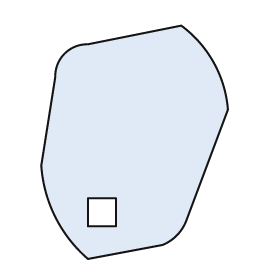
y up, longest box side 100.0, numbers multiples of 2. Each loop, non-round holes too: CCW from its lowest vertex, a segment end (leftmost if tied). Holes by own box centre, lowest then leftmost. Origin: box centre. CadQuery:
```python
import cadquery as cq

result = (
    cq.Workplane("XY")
    .moveTo(-20.0, -50.0)
    .lineTo(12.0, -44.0)
    .threePointArc((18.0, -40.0), (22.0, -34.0))
    .lineTo(40.0, 14.0)
    .threePointArc((34.0, 34.0), (20.0, 50.0))
    .lineTo(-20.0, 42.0)
    .threePointArc((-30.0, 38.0), (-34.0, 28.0))
    .lineTo(-40.0, -10.0)
    .threePointArc((-34.0, -32.0), (-20.0, -50.0))
    .close()
    .moveTo(-20.0, -36.0)
    .lineTo(-8.0, -36.0)
    .lineTo(-8.0, -24.0)
    .lineTo(-20.0, -24.0)
    .close()
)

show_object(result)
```